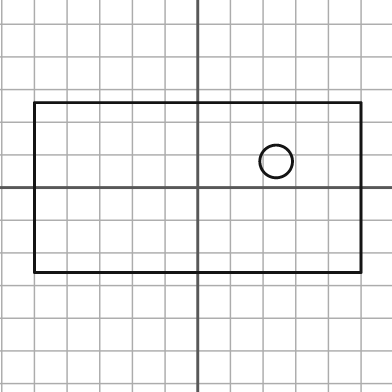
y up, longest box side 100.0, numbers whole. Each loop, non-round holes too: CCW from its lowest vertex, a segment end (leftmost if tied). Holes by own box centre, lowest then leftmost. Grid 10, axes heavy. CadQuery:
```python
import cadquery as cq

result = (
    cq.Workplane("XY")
    .moveTo(-50.0, -26.0)
    .lineTo(50.0, -26.0)
    .lineTo(50.0, 26.0)
    .lineTo(-50.0, 26.0)
    .close()
    .moveTo(24.0, 8.0)
    .circle(5.0)
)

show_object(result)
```